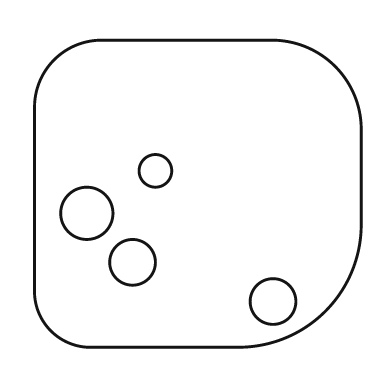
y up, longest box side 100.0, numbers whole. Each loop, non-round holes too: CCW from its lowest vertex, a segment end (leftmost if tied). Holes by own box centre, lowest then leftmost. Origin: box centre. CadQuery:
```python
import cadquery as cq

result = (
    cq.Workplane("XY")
    .moveTo(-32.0, -47.0)
    .lineTo(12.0, -47.0)
    .threePointArc((39.0, -36.0), (50.0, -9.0))
    .lineTo(50.0, 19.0)
    .threePointArc((42.0, 39.0), (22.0, 47.0))
    .lineTo(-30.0, 47.0)
    .threePointArc((-44.0, 41.0), (-50.0, 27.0))
    .lineTo(-50.0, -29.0)
    .threePointArc((-45.0, -42.0), (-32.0, -47.0))
    .close()
    .moveTo(23.0, -33.0)
    .circle(7.0)
    .moveTo(-20.0, -21.0)
    .circle(7.0)
    .moveTo(-34.0, -6.0)
    .circle(8.0)
    .moveTo(-13.0, 7.0)
    .circle(5.0)
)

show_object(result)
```